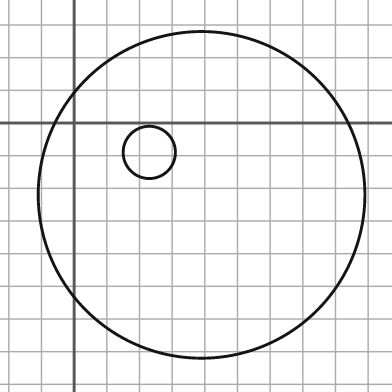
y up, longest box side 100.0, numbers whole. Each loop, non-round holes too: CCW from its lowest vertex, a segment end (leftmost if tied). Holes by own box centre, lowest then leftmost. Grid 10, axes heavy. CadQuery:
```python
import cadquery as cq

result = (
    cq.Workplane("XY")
    .moveTo(39.0, -22.0)
    .circle(50.0)
    .moveTo(23.0, -9.0)
    .circle(8.0)
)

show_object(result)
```